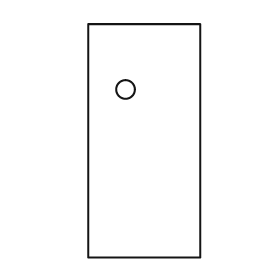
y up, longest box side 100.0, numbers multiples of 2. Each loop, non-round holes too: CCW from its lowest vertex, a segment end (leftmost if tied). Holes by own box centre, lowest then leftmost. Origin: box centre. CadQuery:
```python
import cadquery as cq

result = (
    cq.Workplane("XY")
    .moveTo(-24.0, -50.0)
    .lineTo(24.0, -50.0)
    .lineTo(24.0, 50.0)
    .lineTo(-24.0, 50.0)
    .close()
    .moveTo(-8.0, 22.0)
    .circle(4.0)
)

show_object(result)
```